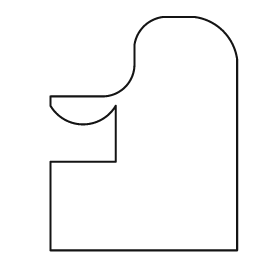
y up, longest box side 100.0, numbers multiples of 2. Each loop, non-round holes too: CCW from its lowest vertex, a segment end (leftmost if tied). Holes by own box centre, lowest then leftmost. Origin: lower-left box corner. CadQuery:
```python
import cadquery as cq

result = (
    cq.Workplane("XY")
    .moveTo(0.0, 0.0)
    .lineTo(80.0, 0.0)
    .lineTo(80.0, 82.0)
    .threePointArc((74.0, 94.0), (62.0, 100.0))
    .lineTo(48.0, 100.0)
    .threePointArc((40.0, 96.0), (36.0, 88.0))
    .lineTo(36.0, 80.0)
    .threePointArc((32.0, 70.0), (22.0, 66.0))
    .lineTo(0.0, 66.0)
    .lineTo(0.0, 62.0)
    .threePointArc((14.0, 54.0), (28.0, 62.0))
    .lineTo(28.0, 38.0)
    .lineTo(0.0, 38.0)
    .close()
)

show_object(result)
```